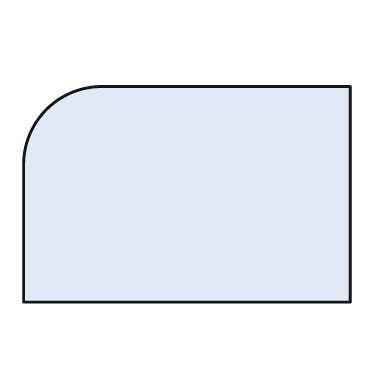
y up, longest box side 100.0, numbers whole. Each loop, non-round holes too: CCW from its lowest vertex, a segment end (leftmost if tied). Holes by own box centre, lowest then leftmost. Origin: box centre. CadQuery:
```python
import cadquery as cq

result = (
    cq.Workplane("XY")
    .moveTo(-50.0, -33.0)
    .lineTo(50.0, -33.0)
    .lineTo(50.0, 33.0)
    .lineTo(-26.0, 33.0)
    .threePointArc((-43.0, 26.0), (-50.0, 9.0))
    .close()
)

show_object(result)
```